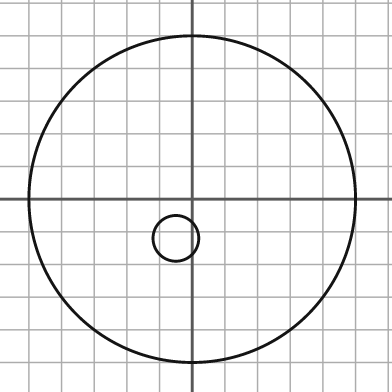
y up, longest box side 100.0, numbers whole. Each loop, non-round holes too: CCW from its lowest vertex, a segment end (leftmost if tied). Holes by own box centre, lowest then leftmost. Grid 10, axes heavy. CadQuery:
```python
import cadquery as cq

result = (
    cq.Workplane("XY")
    .moveTo(0.0, 0.0)
    .circle(50.0)
    .moveTo(-5.0, -12.0)
    .circle(7.0)
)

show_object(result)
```